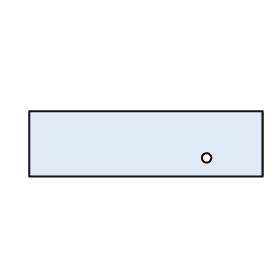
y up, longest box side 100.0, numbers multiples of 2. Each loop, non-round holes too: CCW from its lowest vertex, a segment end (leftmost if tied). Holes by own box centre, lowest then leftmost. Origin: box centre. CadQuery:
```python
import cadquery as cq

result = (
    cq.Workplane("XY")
    .moveTo(-50.0, -14.0)
    .lineTo(50.0, -14.0)
    .lineTo(50.0, 14.0)
    .lineTo(-50.0, 14.0)
    .close()
    .moveTo(26.0, -6.0)
    .circle(2.0)
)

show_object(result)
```